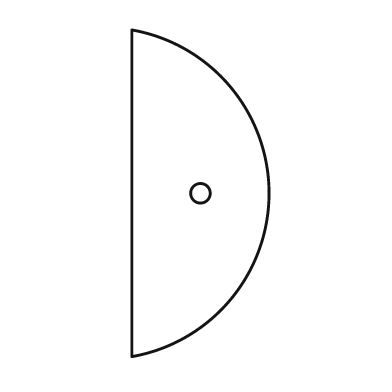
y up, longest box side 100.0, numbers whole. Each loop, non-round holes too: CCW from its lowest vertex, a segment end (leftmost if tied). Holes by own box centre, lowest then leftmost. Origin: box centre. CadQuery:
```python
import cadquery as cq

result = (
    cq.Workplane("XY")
    .moveTo(-21.0, -50.0)
    .threePointArc((21.0, 0.0), (-21.0, 50.0))
    .close()
    .moveTo(0.0, 0.0)
    .circle(3.0)
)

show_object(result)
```